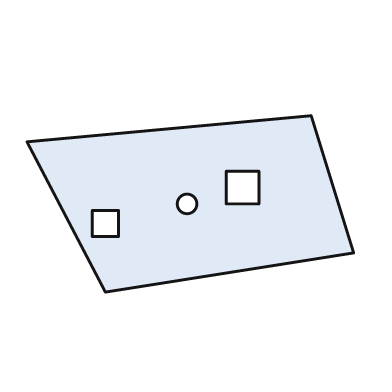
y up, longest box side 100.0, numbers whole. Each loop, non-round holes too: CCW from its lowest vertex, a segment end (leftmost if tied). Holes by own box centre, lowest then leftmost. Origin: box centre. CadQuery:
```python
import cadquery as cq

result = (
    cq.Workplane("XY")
    .moveTo(-26.0, -27.0)
    .lineTo(50.0, -15.0)
    .lineTo(37.0, 27.0)
    .lineTo(-50.0, 19.0)
    .close()
    .moveTo(-30.0, -10.0)
    .lineTo(-22.0, -10.0)
    .lineTo(-22.0, -2.0)
    .lineTo(-30.0, -2.0)
    .close()
    .moveTo(-1.0, 0.0)
    .circle(3.0)
    .moveTo(11.0, 0.0)
    .lineTo(21.0, 0.0)
    .lineTo(21.0, 10.0)
    .lineTo(11.0, 10.0)
    .close()
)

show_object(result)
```